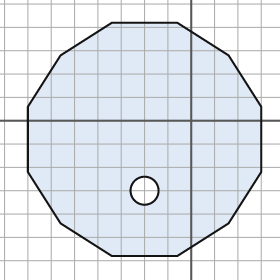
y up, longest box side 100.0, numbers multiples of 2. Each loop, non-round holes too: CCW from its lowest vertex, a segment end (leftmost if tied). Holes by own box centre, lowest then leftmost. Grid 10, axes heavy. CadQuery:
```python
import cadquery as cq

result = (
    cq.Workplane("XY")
    .moveTo(-34.0, -58.0)
    .lineTo(-6.0, -58.0)
    .lineTo(16.0, -44.0)
    .lineTo(30.0, -22.0)
    .lineTo(30.0, 6.0)
    .lineTo(16.0, 28.0)
    .lineTo(-6.0, 42.0)
    .lineTo(-34.0, 42.0)
    .lineTo(-56.0, 28.0)
    .lineTo(-70.0, 6.0)
    .lineTo(-70.0, -22.0)
    .lineTo(-56.0, -44.0)
    .close()
    .moveTo(-20.0, -30.0)
    .circle(6.0)
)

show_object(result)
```